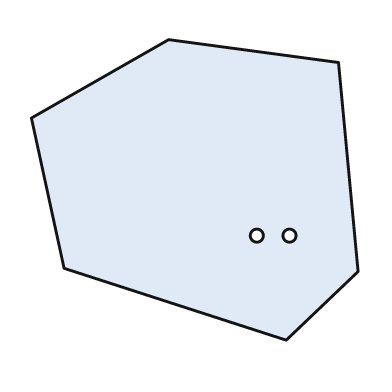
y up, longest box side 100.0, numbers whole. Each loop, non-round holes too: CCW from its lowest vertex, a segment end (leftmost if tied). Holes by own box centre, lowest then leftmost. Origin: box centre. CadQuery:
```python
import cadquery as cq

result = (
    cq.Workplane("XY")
    .moveTo(28.0, -46.0)
    .lineTo(50.0, -25.0)
    .lineTo(44.0, 39.0)
    .lineTo(-8.0, 46.0)
    .lineTo(-50.0, 22.0)
    .lineTo(-40.0, -24.0)
    .close()
    .moveTo(19.0, -14.0)
    .circle(2.0)
    .moveTo(29.0, -14.0)
    .circle(2.0)
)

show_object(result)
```